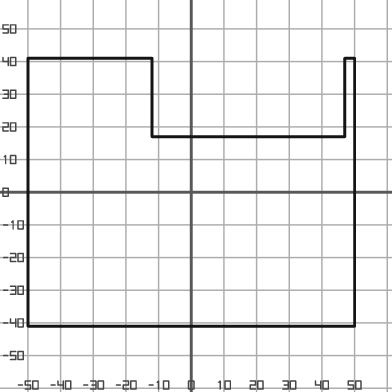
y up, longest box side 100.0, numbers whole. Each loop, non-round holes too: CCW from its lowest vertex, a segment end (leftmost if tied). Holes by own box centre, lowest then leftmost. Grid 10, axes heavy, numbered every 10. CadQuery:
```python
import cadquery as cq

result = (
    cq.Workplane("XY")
    .moveTo(-50.0, -41.0)
    .lineTo(50.0, -41.0)
    .lineTo(50.0, 41.0)
    .lineTo(47.0, 41.0)
    .lineTo(47.0, 17.0)
    .lineTo(-12.0, 17.0)
    .lineTo(-12.0, 41.0)
    .lineTo(-50.0, 41.0)
    .close()
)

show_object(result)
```